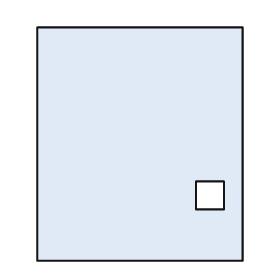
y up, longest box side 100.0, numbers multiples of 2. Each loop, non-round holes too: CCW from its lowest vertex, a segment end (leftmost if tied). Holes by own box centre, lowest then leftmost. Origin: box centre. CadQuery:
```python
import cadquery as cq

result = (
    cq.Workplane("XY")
    .moveTo(-44.0, -50.0)
    .lineTo(44.0, -50.0)
    .lineTo(44.0, 50.0)
    .lineTo(-44.0, 50.0)
    .close()
    .moveTo(24.0, -28.0)
    .lineTo(36.0, -28.0)
    .lineTo(36.0, -16.0)
    .lineTo(24.0, -16.0)
    .close()
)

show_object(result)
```